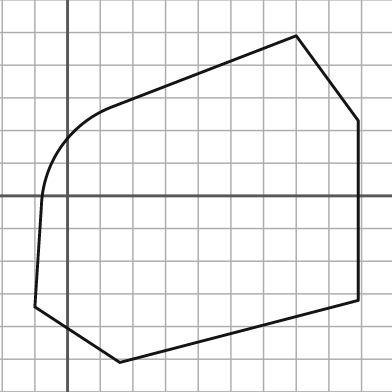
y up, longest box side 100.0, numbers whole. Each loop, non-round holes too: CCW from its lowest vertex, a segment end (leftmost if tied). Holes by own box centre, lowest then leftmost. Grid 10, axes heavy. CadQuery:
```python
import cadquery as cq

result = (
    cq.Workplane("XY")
    .moveTo(16.0, -51.0)
    .lineTo(89.0, -32.0)
    .lineTo(89.0, 23.0)
    .lineTo(70.0, 49.0)
    .lineTo(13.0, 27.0)
    .threePointArc((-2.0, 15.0), (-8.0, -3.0))
    .lineTo(-10.0, -34.0)
    .close()
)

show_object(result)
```